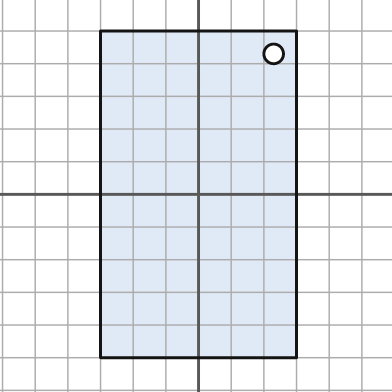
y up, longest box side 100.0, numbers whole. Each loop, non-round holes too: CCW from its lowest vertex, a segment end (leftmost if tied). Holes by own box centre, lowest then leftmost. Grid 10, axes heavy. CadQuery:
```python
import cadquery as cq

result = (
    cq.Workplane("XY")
    .moveTo(-30.0, -50.0)
    .lineTo(30.0, -50.0)
    .lineTo(30.0, 50.0)
    .lineTo(-30.0, 50.0)
    .close()
    .moveTo(23.0, 43.0)
    .circle(3.0)
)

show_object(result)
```